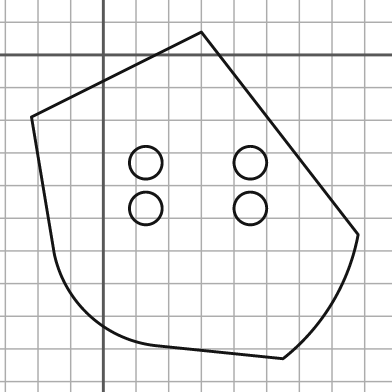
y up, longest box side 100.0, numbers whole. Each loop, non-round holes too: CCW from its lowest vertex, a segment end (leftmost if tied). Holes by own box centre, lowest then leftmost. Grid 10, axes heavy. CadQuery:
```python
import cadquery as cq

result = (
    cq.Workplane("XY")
    .moveTo(55.0, -93.0)
    .threePointArc((70.0, -76.0), (78.0, -55.0))
    .lineTo(30.0, 7.0)
    .lineTo(-22.0, -19.0)
    .lineTo(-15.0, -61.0)
    .threePointArc((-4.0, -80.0), (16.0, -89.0))
    .close()
    .moveTo(13.0, -47.0)
    .circle(5.0)
    .moveTo(45.0, -47.0)
    .circle(5.0)
    .moveTo(13.0, -33.0)
    .circle(5.0)
    .moveTo(45.0, -33.0)
    .circle(5.0)
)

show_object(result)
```